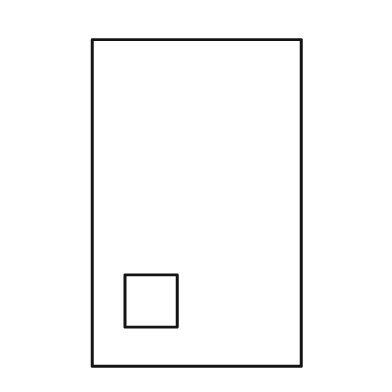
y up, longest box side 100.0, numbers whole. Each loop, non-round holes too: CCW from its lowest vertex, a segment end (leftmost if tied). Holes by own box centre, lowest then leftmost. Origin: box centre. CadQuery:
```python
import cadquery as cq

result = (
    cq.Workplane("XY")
    .moveTo(-32.0, -50.0)
    .lineTo(32.0, -50.0)
    .lineTo(32.0, 50.0)
    .lineTo(-32.0, 50.0)
    .close()
    .moveTo(-22.0, -38.0)
    .lineTo(-6.0, -38.0)
    .lineTo(-6.0, -22.0)
    .lineTo(-22.0, -22.0)
    .close()
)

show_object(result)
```